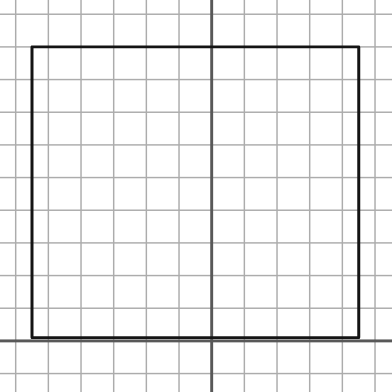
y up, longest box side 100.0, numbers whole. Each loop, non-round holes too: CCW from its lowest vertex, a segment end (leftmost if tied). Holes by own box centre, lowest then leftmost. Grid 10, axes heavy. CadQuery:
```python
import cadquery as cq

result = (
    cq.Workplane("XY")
    .moveTo(-55.0, 1.0)
    .lineTo(45.0, 1.0)
    .lineTo(45.0, 90.0)
    .lineTo(-55.0, 90.0)
    .close()
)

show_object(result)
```